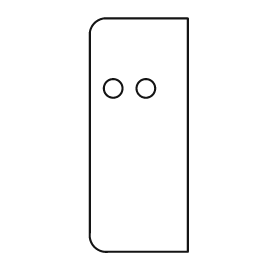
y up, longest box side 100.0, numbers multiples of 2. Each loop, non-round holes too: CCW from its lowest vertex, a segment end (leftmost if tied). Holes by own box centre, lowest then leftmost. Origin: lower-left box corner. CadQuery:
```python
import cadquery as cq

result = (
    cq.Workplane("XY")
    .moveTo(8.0, 0.0)
    .lineTo(42.0, 0.0)
    .lineTo(42.0, 100.0)
    .lineTo(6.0, 100.0)
    .threePointArc((2.0, 98.0), (0.0, 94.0))
    .lineTo(0.0, 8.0)
    .threePointArc((2.0, 2.0), (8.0, 0.0))
    .close()
    .moveTo(10.0, 70.0)
    .circle(4.0)
    .moveTo(24.0, 70.0)
    .circle(4.0)
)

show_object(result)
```